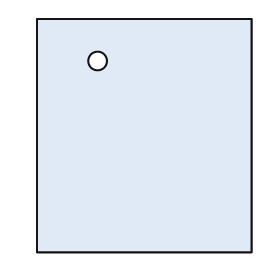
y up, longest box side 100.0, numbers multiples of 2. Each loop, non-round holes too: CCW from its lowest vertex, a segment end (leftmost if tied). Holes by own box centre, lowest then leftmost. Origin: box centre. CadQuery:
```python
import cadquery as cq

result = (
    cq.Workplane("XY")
    .moveTo(-46.0, -50.0)
    .lineTo(46.0, -50.0)
    .lineTo(46.0, 50.0)
    .lineTo(-46.0, 50.0)
    .close()
    .moveTo(-20.0, 32.0)
    .circle(4.0)
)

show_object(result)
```